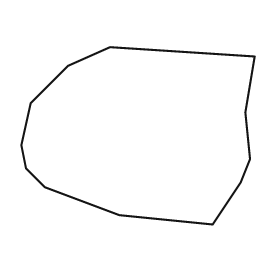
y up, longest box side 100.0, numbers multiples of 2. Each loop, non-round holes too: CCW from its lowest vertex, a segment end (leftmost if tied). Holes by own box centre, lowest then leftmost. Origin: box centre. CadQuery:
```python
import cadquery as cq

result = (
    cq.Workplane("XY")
    .moveTo(32.0, -38.0)
    .lineTo(44.0, -20.0)
    .lineTo(48.0, -10.0)
    .lineTo(46.0, 10.0)
    .lineTo(50.0, 34.0)
    .lineTo(-12.0, 38.0)
    .lineTo(-30.0, 30.0)
    .lineTo(-46.0, 14.0)
    .lineTo(-50.0, -4.0)
    .lineTo(-48.0, -14.0)
    .lineTo(-40.0, -22.0)
    .lineTo(-8.0, -34.0)
    .close()
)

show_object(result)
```